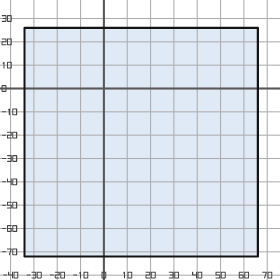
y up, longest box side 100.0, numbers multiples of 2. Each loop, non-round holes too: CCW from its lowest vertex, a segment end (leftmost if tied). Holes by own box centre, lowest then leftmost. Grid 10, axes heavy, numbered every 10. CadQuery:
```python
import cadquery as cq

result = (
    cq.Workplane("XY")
    .moveTo(-34.0, -72.0)
    .lineTo(66.0, -72.0)
    .lineTo(66.0, 26.0)
    .lineTo(-34.0, 26.0)
    .close()
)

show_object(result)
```